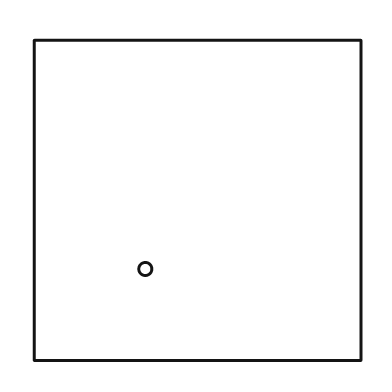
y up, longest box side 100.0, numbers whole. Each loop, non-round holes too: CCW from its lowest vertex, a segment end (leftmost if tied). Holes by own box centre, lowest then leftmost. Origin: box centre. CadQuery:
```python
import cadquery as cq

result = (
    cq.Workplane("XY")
    .moveTo(-50.0, -49.0)
    .lineTo(50.0, -49.0)
    .lineTo(50.0, 49.0)
    .lineTo(-50.0, 49.0)
    .close()
    .moveTo(-16.0, -21.0)
    .circle(2.0)
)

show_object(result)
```